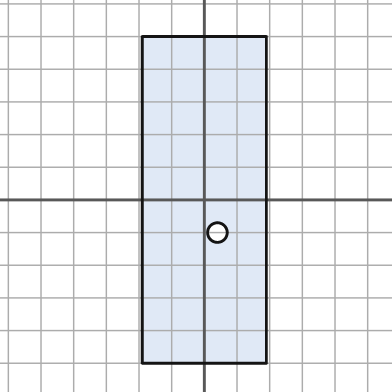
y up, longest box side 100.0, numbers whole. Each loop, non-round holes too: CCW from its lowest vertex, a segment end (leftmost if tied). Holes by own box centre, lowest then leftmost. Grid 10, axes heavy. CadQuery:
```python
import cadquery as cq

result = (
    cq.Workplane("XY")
    .moveTo(-19.0, -50.0)
    .lineTo(19.0, -50.0)
    .lineTo(19.0, 50.0)
    .lineTo(-19.0, 50.0)
    .close()
    .moveTo(4.0, -10.0)
    .circle(3.0)
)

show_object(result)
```